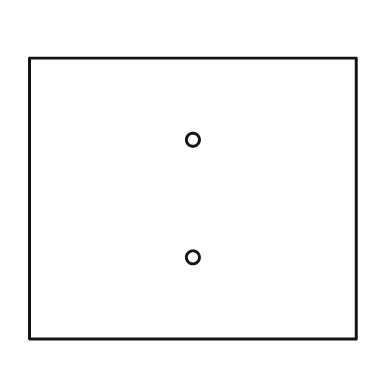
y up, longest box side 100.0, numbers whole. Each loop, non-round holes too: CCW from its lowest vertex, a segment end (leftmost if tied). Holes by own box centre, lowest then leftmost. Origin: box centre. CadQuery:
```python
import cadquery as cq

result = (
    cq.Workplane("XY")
    .moveTo(-50.0, -43.0)
    .lineTo(50.0, -43.0)
    .lineTo(50.0, 43.0)
    .lineTo(-50.0, 43.0)
    .close()
    .moveTo(0.0, -18.0)
    .circle(2.0)
    .moveTo(0.0, 18.0)
    .circle(2.0)
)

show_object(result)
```